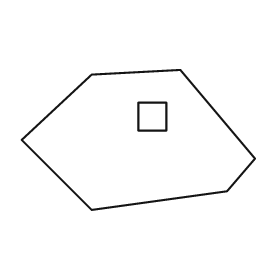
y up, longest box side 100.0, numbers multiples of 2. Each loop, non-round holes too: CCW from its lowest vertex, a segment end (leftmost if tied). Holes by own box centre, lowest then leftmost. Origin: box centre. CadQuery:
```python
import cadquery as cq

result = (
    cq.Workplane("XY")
    .moveTo(-20.0, -30.0)
    .lineTo(38.0, -22.0)
    .lineTo(50.0, -8.0)
    .lineTo(18.0, 30.0)
    .lineTo(-20.0, 28.0)
    .lineTo(-50.0, 0.0)
    .close()
    .moveTo(0.0, 4.0)
    .lineTo(12.0, 4.0)
    .lineTo(12.0, 16.0)
    .lineTo(0.0, 16.0)
    .close()
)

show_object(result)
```